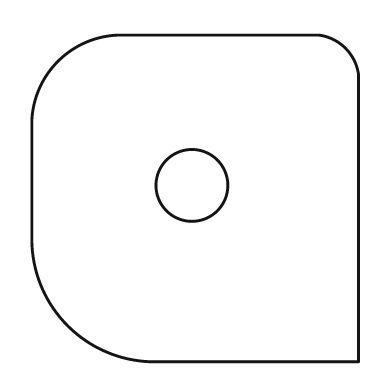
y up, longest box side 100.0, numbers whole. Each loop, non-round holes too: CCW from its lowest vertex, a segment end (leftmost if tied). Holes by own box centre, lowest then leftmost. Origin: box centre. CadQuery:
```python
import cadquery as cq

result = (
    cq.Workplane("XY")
    .moveTo(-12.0, -50.0)
    .lineTo(50.0, -50.0)
    .lineTo(50.0, 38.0)
    .threePointArc((46.0, 46.0), (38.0, 50.0))
    .lineTo(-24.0, 50.0)
    .threePointArc((-42.0, 42.0), (-50.0, 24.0))
    .lineTo(-50.0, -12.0)
    .threePointArc((-39.0, -39.0), (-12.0, -50.0))
    .close()
    .moveTo(-1.0, 4.0)
    .circle(11.0)
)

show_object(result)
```